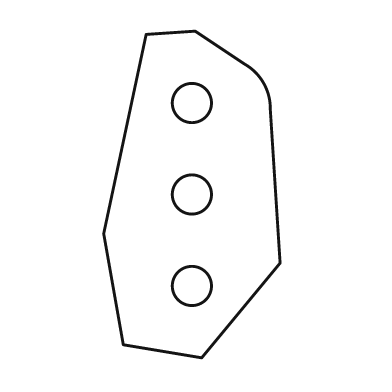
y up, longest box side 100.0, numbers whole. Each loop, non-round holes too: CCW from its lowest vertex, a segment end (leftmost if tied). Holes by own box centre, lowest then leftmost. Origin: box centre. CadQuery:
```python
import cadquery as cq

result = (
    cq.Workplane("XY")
    .moveTo(3.0, -50.0)
    .lineTo(27.0, -21.0)
    .lineTo(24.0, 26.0)
    .threePointArc((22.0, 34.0), (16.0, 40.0))
    .lineTo(1.0, 50.0)
    .lineTo(-14.0, 49.0)
    .lineTo(-27.0, -12.0)
    .lineTo(-21.0, -46.0)
    .close()
    .moveTo(0.0, -28.0)
    .circle(6.0)
    .moveTo(0.0, 0.0)
    .circle(6.0)
    .moveTo(0.0, 28.0)
    .circle(6.0)
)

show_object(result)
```